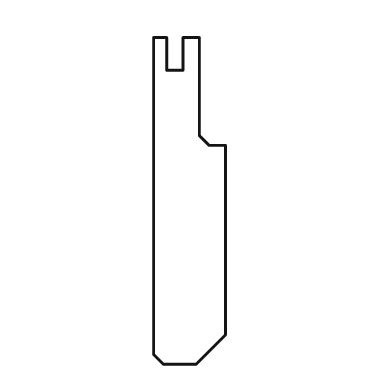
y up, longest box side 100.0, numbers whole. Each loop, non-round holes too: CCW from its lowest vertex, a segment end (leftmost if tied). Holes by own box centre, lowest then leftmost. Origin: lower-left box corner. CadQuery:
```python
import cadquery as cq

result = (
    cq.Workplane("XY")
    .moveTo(3.0, 0.0)
    .lineTo(13.0, 0.0)
    .lineTo(22.0, 9.0)
    .lineTo(22.0, 67.0)
    .lineTo(17.0, 67.0)
    .lineTo(14.0, 70.0)
    .lineTo(14.0, 100.0)
    .lineTo(9.0, 100.0)
    .lineTo(9.0, 90.0)
    .lineTo(4.0, 90.0)
    .lineTo(4.0, 100.0)
    .lineTo(0.0, 100.0)
    .lineTo(0.0, 3.0)
    .close()
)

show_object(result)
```